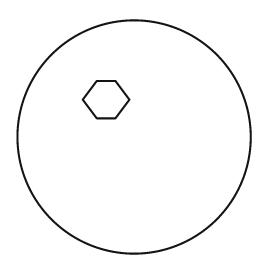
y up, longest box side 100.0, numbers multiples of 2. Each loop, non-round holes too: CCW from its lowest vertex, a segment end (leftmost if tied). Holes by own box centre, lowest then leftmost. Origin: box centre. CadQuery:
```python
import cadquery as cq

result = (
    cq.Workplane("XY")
    .moveTo(0.0, 0.0)
    .circle(50.0)
    .moveTo(-16.0, 8.0)
    .lineTo(-8.0, 8.0)
    .lineTo(-2.0, 16.0)
    .lineTo(-8.0, 24.0)
    .lineTo(-16.0, 24.0)
    .lineTo(-22.0, 16.0)
    .close()
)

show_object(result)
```